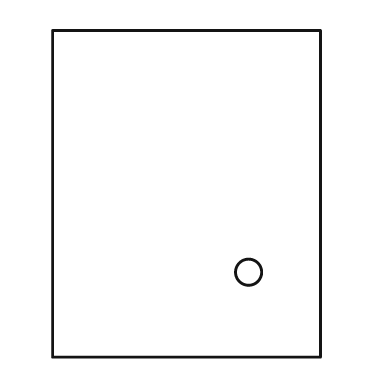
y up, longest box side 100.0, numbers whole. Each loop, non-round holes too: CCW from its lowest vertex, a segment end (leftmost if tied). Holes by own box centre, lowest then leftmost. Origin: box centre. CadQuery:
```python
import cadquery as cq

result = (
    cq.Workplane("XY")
    .moveTo(-41.0, -50.0)
    .lineTo(41.0, -50.0)
    .lineTo(41.0, 50.0)
    .lineTo(-41.0, 50.0)
    .close()
    .moveTo(19.0, -24.0)
    .circle(4.0)
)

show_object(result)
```